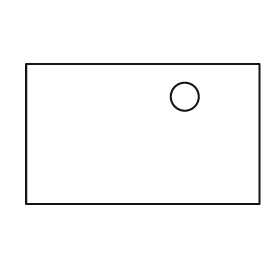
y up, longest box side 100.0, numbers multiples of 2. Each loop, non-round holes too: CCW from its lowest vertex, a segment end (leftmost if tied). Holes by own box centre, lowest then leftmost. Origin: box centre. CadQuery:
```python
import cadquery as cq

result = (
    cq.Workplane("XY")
    .moveTo(-50.0, -30.0)
    .lineTo(50.0, -30.0)
    .lineTo(50.0, 30.0)
    .lineTo(-50.0, 30.0)
    .close()
    .moveTo(18.0, 16.0)
    .circle(6.0)
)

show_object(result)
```